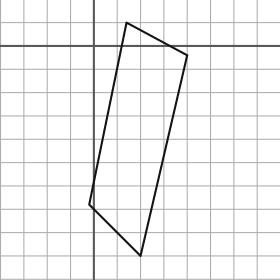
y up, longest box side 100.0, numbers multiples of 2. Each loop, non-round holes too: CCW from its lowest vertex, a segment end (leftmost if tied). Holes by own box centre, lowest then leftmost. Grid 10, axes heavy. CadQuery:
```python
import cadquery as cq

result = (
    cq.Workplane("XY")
    .moveTo(20.0, -90.0)
    .lineTo(40.0, -4.0)
    .lineTo(14.0, 10.0)
    .lineTo(-2.0, -68.0)
    .close()
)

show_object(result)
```